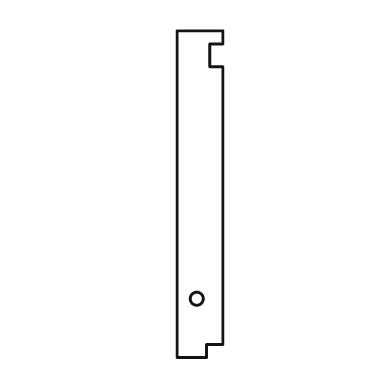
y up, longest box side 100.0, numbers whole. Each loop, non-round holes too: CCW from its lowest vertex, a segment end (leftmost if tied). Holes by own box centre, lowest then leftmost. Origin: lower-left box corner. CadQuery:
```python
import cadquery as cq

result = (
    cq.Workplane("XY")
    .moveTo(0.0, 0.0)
    .lineTo(9.0, 0.0)
    .lineTo(9.0, 4.0)
    .lineTo(14.0, 4.0)
    .lineTo(14.0, 89.0)
    .lineTo(10.0, 89.0)
    .lineTo(10.0, 96.0)
    .lineTo(14.0, 96.0)
    .lineTo(14.0, 100.0)
    .lineTo(0.0, 100.0)
    .close()
    .moveTo(6.0, 18.0)
    .circle(2.0)
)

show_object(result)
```